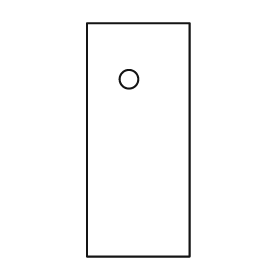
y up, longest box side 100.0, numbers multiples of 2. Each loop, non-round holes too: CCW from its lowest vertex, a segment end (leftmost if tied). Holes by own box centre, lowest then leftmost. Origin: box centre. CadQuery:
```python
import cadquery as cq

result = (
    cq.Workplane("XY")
    .moveTo(-22.0, -50.0)
    .lineTo(22.0, -50.0)
    .lineTo(22.0, 50.0)
    .lineTo(-22.0, 50.0)
    .close()
    .moveTo(-4.0, 26.0)
    .circle(4.0)
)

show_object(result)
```